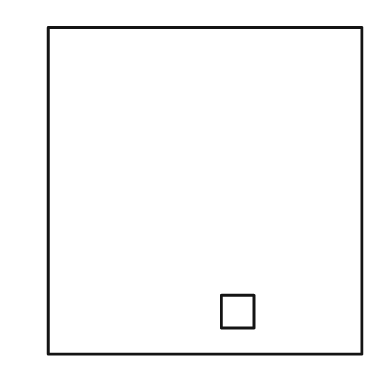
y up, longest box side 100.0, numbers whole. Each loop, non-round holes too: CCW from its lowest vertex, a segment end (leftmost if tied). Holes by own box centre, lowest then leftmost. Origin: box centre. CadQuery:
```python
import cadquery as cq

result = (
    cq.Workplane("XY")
    .moveTo(-48.0, -50.0)
    .lineTo(48.0, -50.0)
    .lineTo(48.0, 50.0)
    .lineTo(-48.0, 50.0)
    .close()
    .moveTo(5.0, -42.0)
    .lineTo(15.0, -42.0)
    .lineTo(15.0, -32.0)
    .lineTo(5.0, -32.0)
    .close()
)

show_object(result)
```